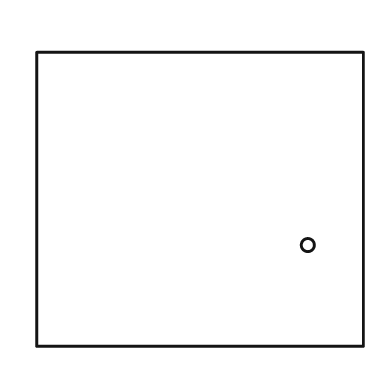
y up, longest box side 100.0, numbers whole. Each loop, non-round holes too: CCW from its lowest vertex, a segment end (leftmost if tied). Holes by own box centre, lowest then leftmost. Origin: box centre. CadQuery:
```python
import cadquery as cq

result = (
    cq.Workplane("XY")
    .moveTo(-50.0, -45.0)
    .lineTo(50.0, -45.0)
    .lineTo(50.0, 45.0)
    .lineTo(-50.0, 45.0)
    .close()
    .moveTo(33.0, -14.0)
    .circle(2.0)
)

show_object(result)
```